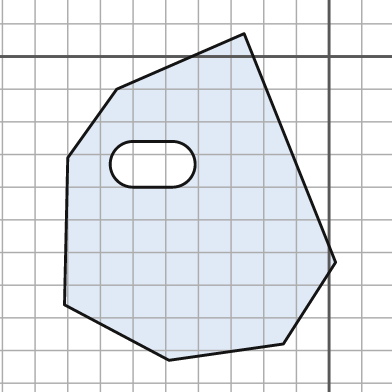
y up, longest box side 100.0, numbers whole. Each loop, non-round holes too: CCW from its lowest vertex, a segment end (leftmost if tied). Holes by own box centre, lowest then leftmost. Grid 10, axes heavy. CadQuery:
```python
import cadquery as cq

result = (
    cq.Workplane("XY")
    .moveTo(-49.0, -93.0)
    .lineTo(-14.0, -88.0)
    .lineTo(2.0, -63.0)
    .lineTo(-26.0, 7.0)
    .lineTo(-65.0, -10.0)
    .lineTo(-80.0, -31.0)
    .lineTo(-81.0, -76.0)
    .close()
    .moveTo(-60.0, -40.0)
    .lineTo(-48.0, -40.0)
    .threePointArc((-41.0, -33.0), (-48.0, -26.0))
    .lineTo(-60.0, -26.0)
    .threePointArc((-67.0, -33.0), (-60.0, -40.0))
    .close()
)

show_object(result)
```